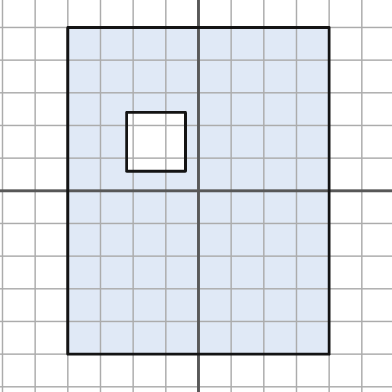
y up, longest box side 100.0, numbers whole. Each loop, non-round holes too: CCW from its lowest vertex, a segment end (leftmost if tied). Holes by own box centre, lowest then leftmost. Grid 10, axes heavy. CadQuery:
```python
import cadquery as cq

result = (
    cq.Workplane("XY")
    .moveTo(-40.0, -50.0)
    .lineTo(40.0, -50.0)
    .lineTo(40.0, 50.0)
    .lineTo(-40.0, 50.0)
    .close()
    .moveTo(-22.0, 6.0)
    .lineTo(-4.0, 6.0)
    .lineTo(-4.0, 24.0)
    .lineTo(-22.0, 24.0)
    .close()
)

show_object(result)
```